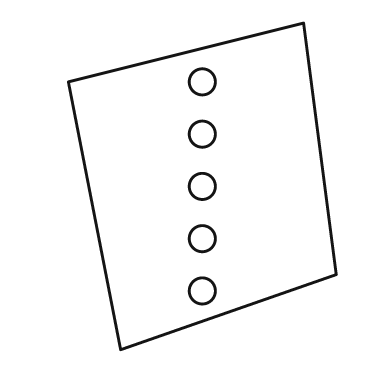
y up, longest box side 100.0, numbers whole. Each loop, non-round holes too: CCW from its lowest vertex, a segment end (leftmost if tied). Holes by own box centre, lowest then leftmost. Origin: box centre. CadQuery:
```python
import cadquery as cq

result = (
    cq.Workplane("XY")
    .moveTo(-25.0, -50.0)
    .lineTo(41.0, -27.0)
    .lineTo(31.0, 50.0)
    .lineTo(-41.0, 32.0)
    .close()
    .moveTo(0.0, -32.0)
    .circle(4.0)
    .moveTo(0.0, -16.0)
    .circle(4.0)
    .moveTo(0.0, 0.0)
    .circle(4.0)
    .moveTo(0.0, 16.0)
    .circle(4.0)
    .moveTo(0.0, 32.0)
    .circle(4.0)
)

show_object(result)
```